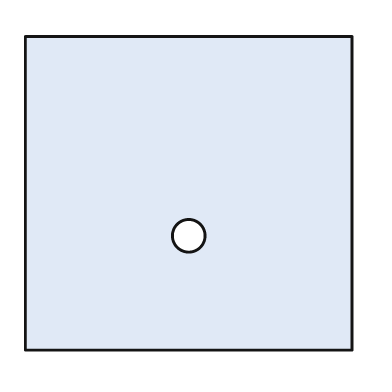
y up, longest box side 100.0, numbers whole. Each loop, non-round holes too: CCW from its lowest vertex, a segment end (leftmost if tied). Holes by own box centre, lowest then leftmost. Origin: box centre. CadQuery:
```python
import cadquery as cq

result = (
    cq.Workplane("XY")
    .moveTo(-50.0, -48.0)
    .lineTo(50.0, -48.0)
    .lineTo(50.0, 48.0)
    .lineTo(-50.0, 48.0)
    .close()
    .moveTo(0.0, -13.0)
    .circle(5.0)
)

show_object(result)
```